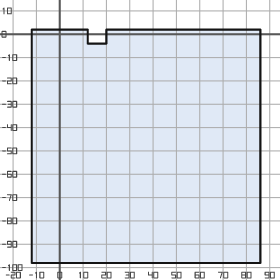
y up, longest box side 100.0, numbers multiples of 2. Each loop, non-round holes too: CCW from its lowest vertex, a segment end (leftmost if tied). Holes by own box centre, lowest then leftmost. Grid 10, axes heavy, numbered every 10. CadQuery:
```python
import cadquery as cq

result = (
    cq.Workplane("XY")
    .moveTo(-12.0, -98.0)
    .lineTo(86.0, -98.0)
    .lineTo(86.0, 2.0)
    .lineTo(20.0, 2.0)
    .lineTo(20.0, -4.0)
    .lineTo(12.0, -4.0)
    .lineTo(12.0, 2.0)
    .lineTo(-12.0, 2.0)
    .close()
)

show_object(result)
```